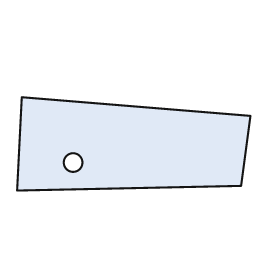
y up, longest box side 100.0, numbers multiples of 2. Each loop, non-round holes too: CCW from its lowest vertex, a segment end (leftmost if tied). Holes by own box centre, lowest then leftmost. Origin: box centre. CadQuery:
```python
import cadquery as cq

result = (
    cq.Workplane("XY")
    .moveTo(-50.0, -20.0)
    .lineTo(46.0, -18.0)
    .lineTo(50.0, 12.0)
    .lineTo(-48.0, 20.0)
    .close()
    .moveTo(-26.0, -8.0)
    .circle(4.0)
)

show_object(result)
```